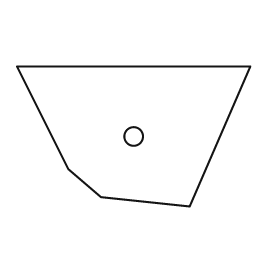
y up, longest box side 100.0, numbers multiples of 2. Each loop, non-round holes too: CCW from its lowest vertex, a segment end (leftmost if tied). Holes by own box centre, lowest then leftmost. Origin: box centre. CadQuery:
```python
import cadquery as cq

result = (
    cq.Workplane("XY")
    .moveTo(24.0, -30.0)
    .lineTo(50.0, 30.0)
    .lineTo(-50.0, 30.0)
    .lineTo(-28.0, -14.0)
    .lineTo(-14.0, -26.0)
    .close()
    .moveTo(0.0, 0.0)
    .circle(4.0)
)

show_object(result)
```